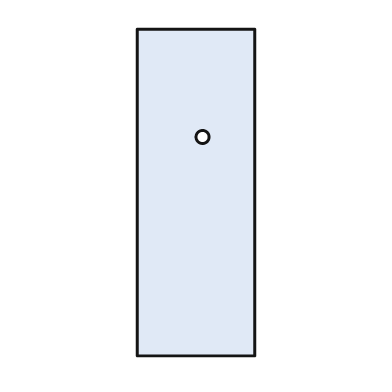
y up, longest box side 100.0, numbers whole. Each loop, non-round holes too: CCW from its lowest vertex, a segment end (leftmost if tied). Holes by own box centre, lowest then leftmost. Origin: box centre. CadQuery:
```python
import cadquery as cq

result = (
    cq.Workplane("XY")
    .moveTo(-18.0, -50.0)
    .lineTo(18.0, -50.0)
    .lineTo(18.0, 50.0)
    .lineTo(-18.0, 50.0)
    .close()
    .moveTo(2.0, 17.0)
    .circle(2.0)
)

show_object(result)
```